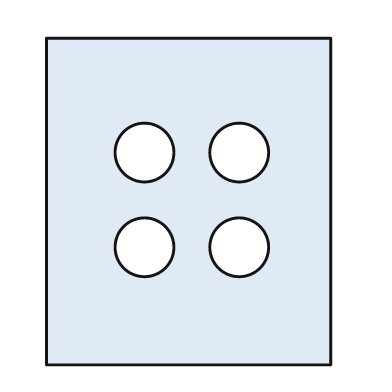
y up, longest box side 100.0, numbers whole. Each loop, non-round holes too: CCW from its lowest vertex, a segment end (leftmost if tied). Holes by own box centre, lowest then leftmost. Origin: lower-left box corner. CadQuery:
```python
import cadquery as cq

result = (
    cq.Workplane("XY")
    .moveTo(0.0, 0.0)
    .lineTo(87.0, 0.0)
    .lineTo(87.0, 100.0)
    .lineTo(0.0, 100.0)
    .close()
    .moveTo(30.0, 36.0)
    .circle(9.0)
    .moveTo(59.0, 36.0)
    .circle(9.0)
    .moveTo(30.0, 65.0)
    .circle(9.0)
    .moveTo(59.0, 65.0)
    .circle(9.0)
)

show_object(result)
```